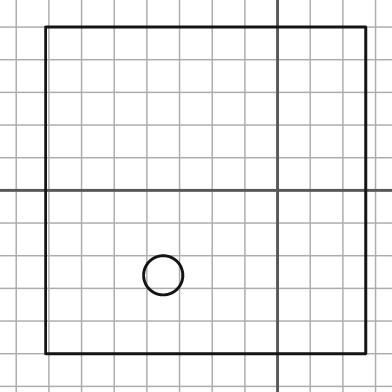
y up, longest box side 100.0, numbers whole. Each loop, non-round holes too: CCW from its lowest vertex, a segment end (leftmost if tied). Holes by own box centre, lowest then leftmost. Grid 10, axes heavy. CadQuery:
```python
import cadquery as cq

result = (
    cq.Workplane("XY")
    .moveTo(-71.0, -50.0)
    .lineTo(27.0, -50.0)
    .lineTo(27.0, 50.0)
    .lineTo(-71.0, 50.0)
    .close()
    .moveTo(-35.0, -26.0)
    .circle(6.0)
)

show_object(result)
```